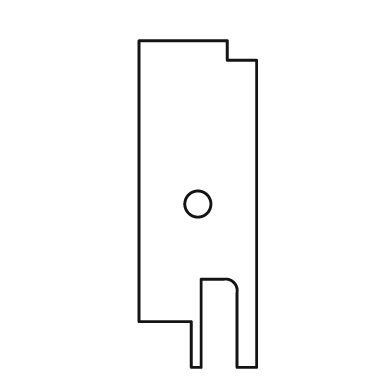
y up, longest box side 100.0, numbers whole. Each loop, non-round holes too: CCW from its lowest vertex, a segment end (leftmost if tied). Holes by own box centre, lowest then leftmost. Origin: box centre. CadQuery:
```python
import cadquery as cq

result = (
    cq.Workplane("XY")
    .moveTo(-2.0, -50.0)
    .lineTo(1.0, -50.0)
    .lineTo(1.0, -23.0)
    .lineTo(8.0, -23.0)
    .threePointArc((11.0, -24.0), (12.0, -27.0))
    .lineTo(12.0, -50.0)
    .lineTo(18.0, -50.0)
    .lineTo(18.0, 44.0)
    .lineTo(9.0, 44.0)
    .lineTo(9.0, 50.0)
    .lineTo(-18.0, 50.0)
    .lineTo(-18.0, -36.0)
    .lineTo(-2.0, -36.0)
    .close()
    .moveTo(0.0, 0.0)
    .circle(4.0)
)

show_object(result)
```